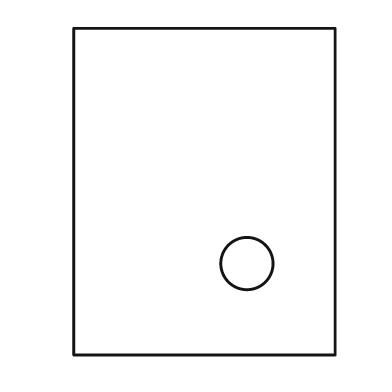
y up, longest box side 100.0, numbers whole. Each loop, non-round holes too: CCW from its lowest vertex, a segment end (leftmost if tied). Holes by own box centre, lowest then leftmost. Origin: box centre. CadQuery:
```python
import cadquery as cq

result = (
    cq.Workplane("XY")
    .moveTo(-40.0, -50.0)
    .lineTo(40.0, -50.0)
    .lineTo(40.0, 50.0)
    .lineTo(-40.0, 50.0)
    .close()
    .moveTo(13.0, -22.0)
    .circle(8.0)
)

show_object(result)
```